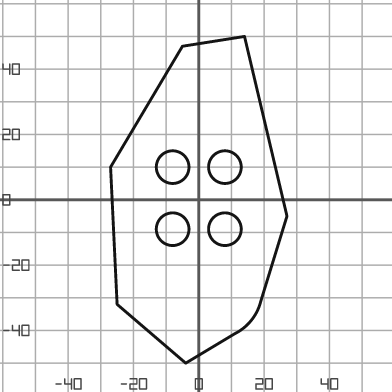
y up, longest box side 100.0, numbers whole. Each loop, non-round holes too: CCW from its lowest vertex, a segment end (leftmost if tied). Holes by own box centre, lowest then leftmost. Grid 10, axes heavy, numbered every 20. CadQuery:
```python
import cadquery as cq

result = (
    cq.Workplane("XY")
    .moveTo(-4.0, -50.0)
    .lineTo(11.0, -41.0)
    .threePointArc((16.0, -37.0), (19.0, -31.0))
    .lineTo(27.0, -5.0)
    .lineTo(14.0, 50.0)
    .lineTo(-5.0, 47.0)
    .lineTo(-27.0, 10.0)
    .lineTo(-25.0, -32.0)
    .close()
    .moveTo(-8.0, -9.0)
    .circle(5.0)
    .moveTo(8.0, -9.0)
    .circle(5.0)
    .moveTo(-8.0, 10.0)
    .circle(5.0)
    .moveTo(8.0, 10.0)
    .circle(5.0)
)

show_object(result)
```